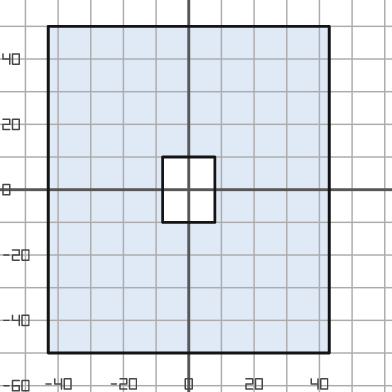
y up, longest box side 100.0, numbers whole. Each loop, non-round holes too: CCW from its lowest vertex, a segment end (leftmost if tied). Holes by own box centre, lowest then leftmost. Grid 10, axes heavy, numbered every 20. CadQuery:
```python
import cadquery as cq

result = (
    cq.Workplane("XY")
    .moveTo(-43.0, -50.0)
    .lineTo(43.0, -50.0)
    .lineTo(43.0, 50.0)
    .lineTo(-43.0, 50.0)
    .close()
    .moveTo(-8.0, -10.0)
    .lineTo(8.0, -10.0)
    .lineTo(8.0, 10.0)
    .lineTo(-8.0, 10.0)
    .close()
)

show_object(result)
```